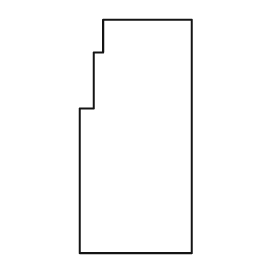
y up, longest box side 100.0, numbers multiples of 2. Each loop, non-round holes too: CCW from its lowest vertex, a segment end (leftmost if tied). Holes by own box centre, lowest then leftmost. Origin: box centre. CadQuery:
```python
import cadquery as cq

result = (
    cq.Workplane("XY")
    .moveTo(-24.0, -50.0)
    .lineTo(24.0, -50.0)
    .lineTo(24.0, 50.0)
    .lineTo(-14.0, 50.0)
    .lineTo(-14.0, 36.0)
    .lineTo(-18.0, 36.0)
    .lineTo(-18.0, 12.0)
    .lineTo(-24.0, 12.0)
    .close()
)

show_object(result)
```